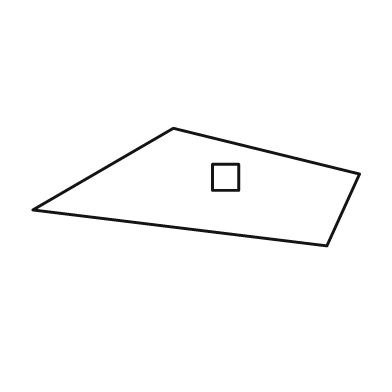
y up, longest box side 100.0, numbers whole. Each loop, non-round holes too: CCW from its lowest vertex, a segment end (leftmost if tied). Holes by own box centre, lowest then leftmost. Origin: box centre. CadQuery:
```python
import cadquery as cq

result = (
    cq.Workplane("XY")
    .moveTo(40.0, -18.0)
    .lineTo(50.0, 4.0)
    .lineTo(-7.0, 18.0)
    .lineTo(-50.0, -7.0)
    .close()
    .moveTo(5.0, -1.0)
    .lineTo(13.0, -1.0)
    .lineTo(13.0, 7.0)
    .lineTo(5.0, 7.0)
    .close()
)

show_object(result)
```